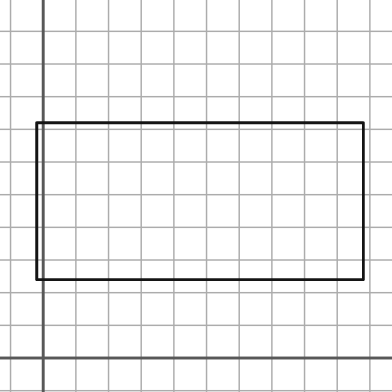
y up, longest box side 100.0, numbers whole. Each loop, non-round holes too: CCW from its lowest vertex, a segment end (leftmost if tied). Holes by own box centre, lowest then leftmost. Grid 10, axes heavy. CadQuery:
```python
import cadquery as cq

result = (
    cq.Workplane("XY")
    .moveTo(-2.0, 24.0)
    .lineTo(98.0, 24.0)
    .lineTo(98.0, 72.0)
    .lineTo(-2.0, 72.0)
    .close()
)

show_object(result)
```